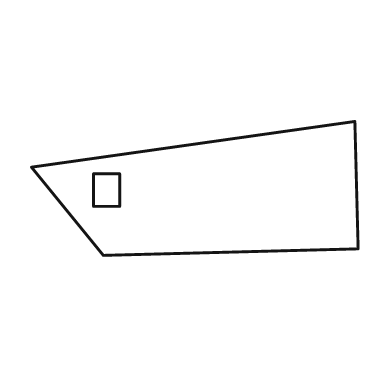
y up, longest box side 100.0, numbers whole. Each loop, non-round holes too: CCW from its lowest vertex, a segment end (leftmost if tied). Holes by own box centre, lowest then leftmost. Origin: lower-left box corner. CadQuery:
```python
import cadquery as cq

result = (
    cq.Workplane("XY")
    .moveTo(22.0, 0.0)
    .lineTo(100.0, 2.0)
    .lineTo(99.0, 41.0)
    .lineTo(0.0, 27.0)
    .close()
    .moveTo(19.0, 15.0)
    .lineTo(27.0, 15.0)
    .lineTo(27.0, 25.0)
    .lineTo(19.0, 25.0)
    .close()
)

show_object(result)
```